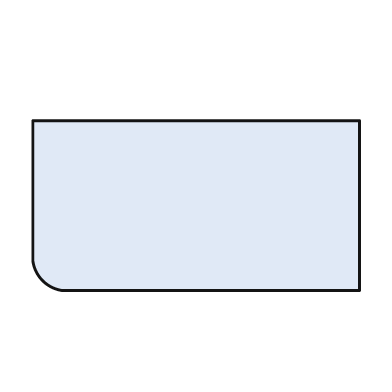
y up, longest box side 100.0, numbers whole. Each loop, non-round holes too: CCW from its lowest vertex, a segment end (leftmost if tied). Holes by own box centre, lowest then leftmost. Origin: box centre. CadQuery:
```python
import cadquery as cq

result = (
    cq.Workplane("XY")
    .moveTo(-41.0, -26.0)
    .lineTo(50.0, -26.0)
    .lineTo(50.0, 26.0)
    .lineTo(-50.0, 26.0)
    .lineTo(-50.0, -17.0)
    .threePointArc((-47.0, -23.0), (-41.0, -26.0))
    .close()
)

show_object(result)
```